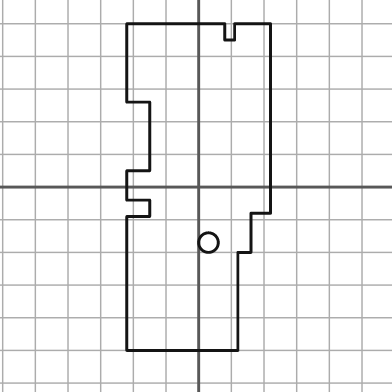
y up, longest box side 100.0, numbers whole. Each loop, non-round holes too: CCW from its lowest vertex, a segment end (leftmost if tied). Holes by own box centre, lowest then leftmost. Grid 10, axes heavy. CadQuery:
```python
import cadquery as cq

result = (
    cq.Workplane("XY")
    .moveTo(-22.0, -50.0)
    .lineTo(12.0, -50.0)
    .lineTo(12.0, -20.0)
    .lineTo(16.0, -20.0)
    .lineTo(16.0, -8.0)
    .lineTo(22.0, -8.0)
    .lineTo(22.0, 50.0)
    .lineTo(11.0, 50.0)
    .lineTo(11.0, 45.0)
    .lineTo(8.0, 45.0)
    .lineTo(8.0, 50.0)
    .lineTo(-22.0, 50.0)
    .lineTo(-22.0, 26.0)
    .lineTo(-15.0, 26.0)
    .lineTo(-15.0, 5.0)
    .lineTo(-22.0, 5.0)
    .lineTo(-22.0, -4.0)
    .lineTo(-15.0, -4.0)
    .lineTo(-15.0, -9.0)
    .lineTo(-22.0, -9.0)
    .close()
    .moveTo(3.0, -17.0)
    .circle(3.0)
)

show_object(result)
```